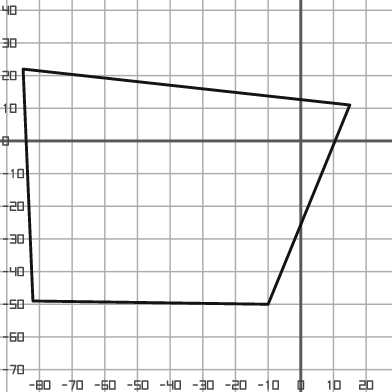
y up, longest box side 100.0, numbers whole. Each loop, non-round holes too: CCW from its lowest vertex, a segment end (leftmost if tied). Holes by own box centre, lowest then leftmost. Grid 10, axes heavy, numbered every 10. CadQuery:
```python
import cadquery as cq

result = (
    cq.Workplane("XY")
    .moveTo(-10.0, -50.0)
    .lineTo(15.0, 11.0)
    .lineTo(-85.0, 22.0)
    .lineTo(-82.0, -49.0)
    .close()
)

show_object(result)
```